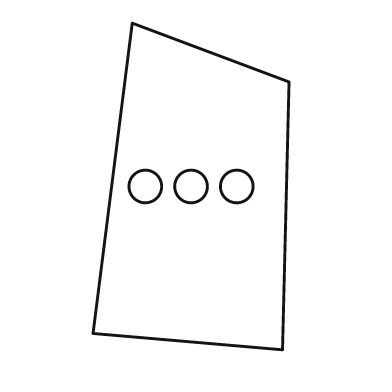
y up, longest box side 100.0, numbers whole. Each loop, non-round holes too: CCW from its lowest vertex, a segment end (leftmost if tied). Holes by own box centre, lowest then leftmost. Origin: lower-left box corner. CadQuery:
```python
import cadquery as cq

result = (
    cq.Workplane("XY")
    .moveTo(58.0, 0.0)
    .lineTo(60.0, 82.0)
    .lineTo(12.0, 100.0)
    .lineTo(0.0, 5.0)
    .close()
    .moveTo(16.0, 50.0)
    .circle(5.0)
    .moveTo(30.0, 50.0)
    .circle(5.0)
    .moveTo(44.0, 50.0)
    .circle(5.0)
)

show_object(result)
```